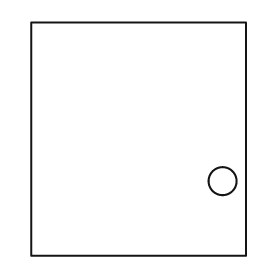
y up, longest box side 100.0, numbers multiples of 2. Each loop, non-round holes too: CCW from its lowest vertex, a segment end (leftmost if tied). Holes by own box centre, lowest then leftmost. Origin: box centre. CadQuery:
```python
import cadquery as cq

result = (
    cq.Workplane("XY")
    .moveTo(-46.0, -50.0)
    .lineTo(46.0, -50.0)
    .lineTo(46.0, 50.0)
    .lineTo(-46.0, 50.0)
    .close()
    .moveTo(36.0, -18.0)
    .circle(6.0)
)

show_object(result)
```